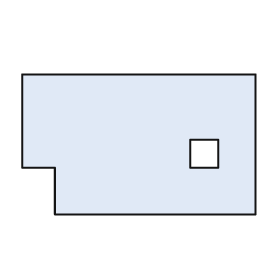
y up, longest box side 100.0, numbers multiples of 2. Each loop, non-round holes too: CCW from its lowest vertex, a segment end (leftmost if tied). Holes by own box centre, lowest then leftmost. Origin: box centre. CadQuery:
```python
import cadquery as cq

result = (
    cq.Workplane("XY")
    .moveTo(-36.0, -30.0)
    .lineTo(50.0, -30.0)
    .lineTo(50.0, 30.0)
    .lineTo(-50.0, 30.0)
    .lineTo(-50.0, -10.0)
    .lineTo(-36.0, -10.0)
    .close()
    .moveTo(22.0, -10.0)
    .lineTo(34.0, -10.0)
    .lineTo(34.0, 2.0)
    .lineTo(22.0, 2.0)
    .close()
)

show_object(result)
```